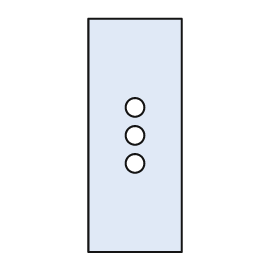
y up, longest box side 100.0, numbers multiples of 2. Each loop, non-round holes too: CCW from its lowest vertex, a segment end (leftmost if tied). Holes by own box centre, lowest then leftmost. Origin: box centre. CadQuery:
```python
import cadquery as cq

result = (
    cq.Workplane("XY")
    .moveTo(-20.0, -50.0)
    .lineTo(20.0, -50.0)
    .lineTo(20.0, 50.0)
    .lineTo(-20.0, 50.0)
    .close()
    .moveTo(0.0, -12.0)
    .circle(4.0)
    .moveTo(0.0, 0.0)
    .circle(4.0)
    .moveTo(0.0, 12.0)
    .circle(4.0)
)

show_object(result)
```